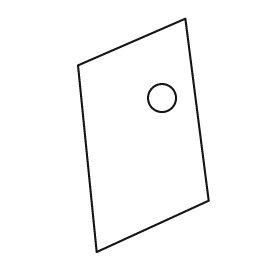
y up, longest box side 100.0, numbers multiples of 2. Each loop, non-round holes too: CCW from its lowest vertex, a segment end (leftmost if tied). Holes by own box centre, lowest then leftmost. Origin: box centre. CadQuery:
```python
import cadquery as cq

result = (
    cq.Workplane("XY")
    .moveTo(-20.0, -50.0)
    .lineTo(28.0, -28.0)
    .lineTo(18.0, 50.0)
    .lineTo(-28.0, 30.0)
    .close()
    .moveTo(8.0, 16.0)
    .circle(6.0)
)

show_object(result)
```